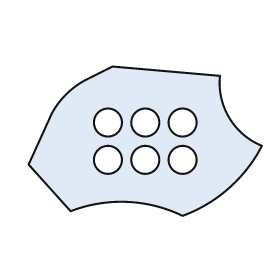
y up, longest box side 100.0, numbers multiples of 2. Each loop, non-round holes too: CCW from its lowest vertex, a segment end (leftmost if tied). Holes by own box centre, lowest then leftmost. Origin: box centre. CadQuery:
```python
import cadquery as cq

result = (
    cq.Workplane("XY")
    .moveTo(16.0, -32.0)
    .threePointArc((36.0, -20.0), (50.0, -2.0))
    .threePointArc((36.0, 10.0), (32.0, 28.0))
    .lineTo(-14.0, 32.0)
    .lineTo(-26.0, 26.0)
    .threePointArc((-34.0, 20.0), (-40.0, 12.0))
    .lineTo(-50.0, -10.0)
    .lineTo(-32.0, -30.0)
    .threePointArc((-8.0, -26.0), (16.0, -32.0))
    .close()
    .moveTo(-16.0, -8.0)
    .circle(6.0)
    .moveTo(0.0, -8.0)
    .circle(6.0)
    .moveTo(16.0, -8.0)
    .circle(6.0)
    .moveTo(-16.0, 8.0)
    .circle(6.0)
    .moveTo(0.0, 8.0)
    .circle(6.0)
    .moveTo(16.0, 8.0)
    .circle(6.0)
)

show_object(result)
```